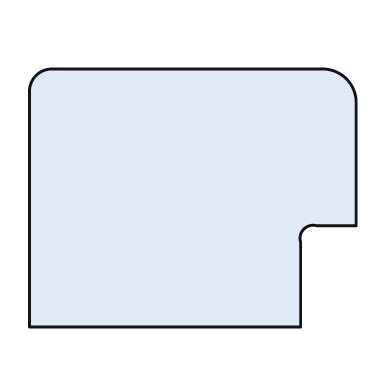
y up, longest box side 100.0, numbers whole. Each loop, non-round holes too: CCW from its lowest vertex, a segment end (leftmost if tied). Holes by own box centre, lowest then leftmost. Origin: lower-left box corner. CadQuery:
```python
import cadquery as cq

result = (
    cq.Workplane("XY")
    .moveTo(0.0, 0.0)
    .lineTo(83.0, 0.0)
    .lineTo(83.0, 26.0)
    .threePointArc((84.0, 30.0), (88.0, 31.0))
    .lineTo(100.0, 31.0)
    .lineTo(100.0, 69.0)
    .threePointArc((97.0, 76.0), (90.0, 79.0))
    .lineTo(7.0, 79.0)
    .threePointArc((2.0, 77.0), (0.0, 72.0))
    .close()
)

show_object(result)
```